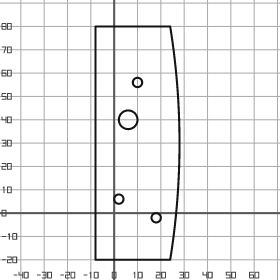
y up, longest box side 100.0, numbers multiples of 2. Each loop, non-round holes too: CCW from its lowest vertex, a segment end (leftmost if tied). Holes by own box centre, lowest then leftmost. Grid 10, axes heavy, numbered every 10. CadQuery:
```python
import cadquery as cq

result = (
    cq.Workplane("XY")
    .moveTo(-8.0, -20.0)
    .lineTo(24.0, -20.0)
    .threePointArc((28.0, 30.0), (24.0, 80.0))
    .lineTo(-8.0, 80.0)
    .close()
    .moveTo(18.0, -2.0)
    .circle(2.0)
    .moveTo(2.0, 6.0)
    .circle(2.0)
    .moveTo(6.0, 40.0)
    .circle(4.0)
    .moveTo(10.0, 56.0)
    .circle(2.0)
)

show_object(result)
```